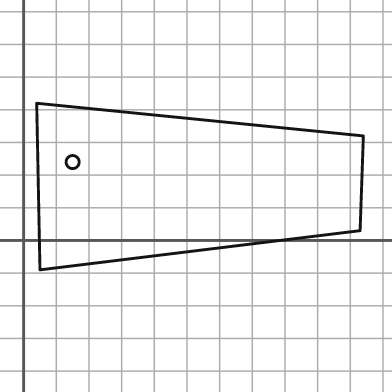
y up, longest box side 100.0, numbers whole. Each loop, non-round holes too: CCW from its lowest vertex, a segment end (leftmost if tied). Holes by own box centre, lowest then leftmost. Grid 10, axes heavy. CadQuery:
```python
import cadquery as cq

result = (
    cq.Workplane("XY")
    .moveTo(5.0, -9.0)
    .lineTo(103.0, 3.0)
    .lineTo(104.0, 32.0)
    .lineTo(4.0, 42.0)
    .close()
    .moveTo(15.0, 24.0)
    .circle(2.0)
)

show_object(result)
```